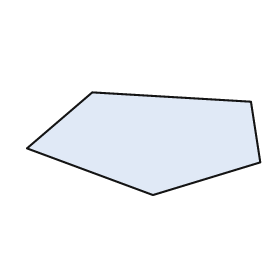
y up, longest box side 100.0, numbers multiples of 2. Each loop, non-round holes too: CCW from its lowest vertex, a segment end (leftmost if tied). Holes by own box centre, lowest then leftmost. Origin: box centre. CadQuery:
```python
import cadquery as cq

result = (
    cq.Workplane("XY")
    .moveTo(4.0, -22.0)
    .lineTo(50.0, -8.0)
    .lineTo(46.0, 18.0)
    .lineTo(-22.0, 22.0)
    .lineTo(-50.0, -2.0)
    .close()
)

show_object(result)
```